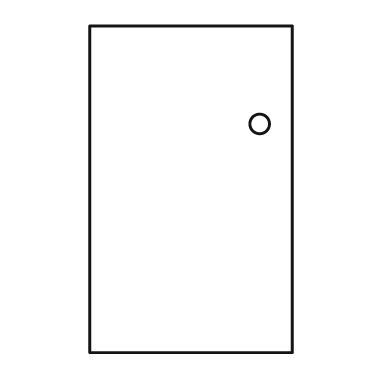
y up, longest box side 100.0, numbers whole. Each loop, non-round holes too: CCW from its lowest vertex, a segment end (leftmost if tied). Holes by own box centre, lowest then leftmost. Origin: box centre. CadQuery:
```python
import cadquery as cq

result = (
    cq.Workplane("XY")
    .moveTo(-31.0, -50.0)
    .lineTo(31.0, -50.0)
    .lineTo(31.0, 50.0)
    .lineTo(-31.0, 50.0)
    .close()
    .moveTo(21.0, 20.0)
    .circle(3.0)
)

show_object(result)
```